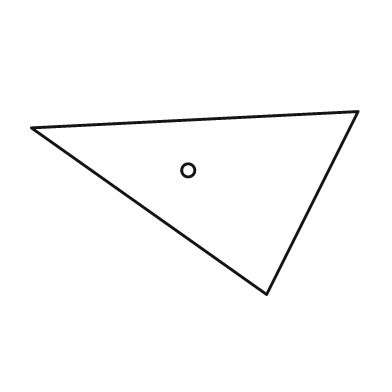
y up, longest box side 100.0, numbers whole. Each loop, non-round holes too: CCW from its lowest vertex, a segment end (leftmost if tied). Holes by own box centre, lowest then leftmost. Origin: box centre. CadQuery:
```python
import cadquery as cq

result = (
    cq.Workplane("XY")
    .moveTo(22.0, -28.0)
    .lineTo(50.0, 28.0)
    .lineTo(-50.0, 23.0)
    .close()
    .moveTo(-2.0, 10.0)
    .circle(2.0)
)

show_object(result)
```